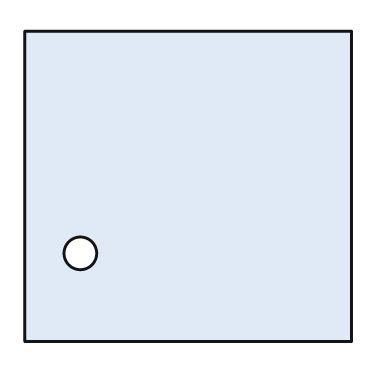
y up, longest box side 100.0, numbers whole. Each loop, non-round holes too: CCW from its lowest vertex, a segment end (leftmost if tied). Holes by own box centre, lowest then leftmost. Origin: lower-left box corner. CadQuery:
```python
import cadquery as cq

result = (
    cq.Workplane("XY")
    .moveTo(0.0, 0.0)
    .lineTo(100.0, 0.0)
    .lineTo(100.0, 95.0)
    .lineTo(0.0, 95.0)
    .close()
    .moveTo(17.0, 27.0)
    .circle(5.0)
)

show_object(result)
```